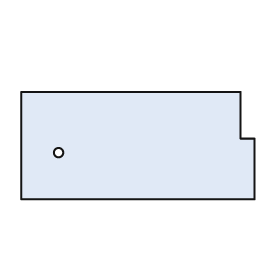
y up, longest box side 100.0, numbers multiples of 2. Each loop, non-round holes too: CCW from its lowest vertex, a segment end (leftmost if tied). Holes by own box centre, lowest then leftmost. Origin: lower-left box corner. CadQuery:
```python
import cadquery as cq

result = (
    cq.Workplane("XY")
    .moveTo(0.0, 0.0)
    .lineTo(100.0, 0.0)
    .lineTo(100.0, 26.0)
    .lineTo(94.0, 26.0)
    .lineTo(94.0, 46.0)
    .lineTo(0.0, 46.0)
    .close()
    .moveTo(16.0, 20.0)
    .circle(2.0)
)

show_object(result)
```